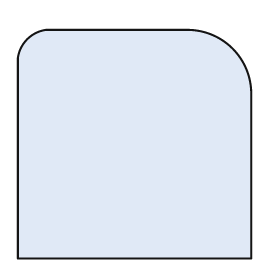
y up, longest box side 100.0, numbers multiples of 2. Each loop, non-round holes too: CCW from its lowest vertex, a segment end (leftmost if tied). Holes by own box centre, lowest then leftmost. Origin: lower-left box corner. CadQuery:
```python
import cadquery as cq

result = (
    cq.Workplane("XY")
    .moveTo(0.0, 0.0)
    .lineTo(100.0, 0.0)
    .lineTo(100.0, 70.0)
    .threePointArc((92.0, 90.0), (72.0, 98.0))
    .lineTo(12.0, 98.0)
    .threePointArc((4.0, 94.0), (0.0, 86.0))
    .close()
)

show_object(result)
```